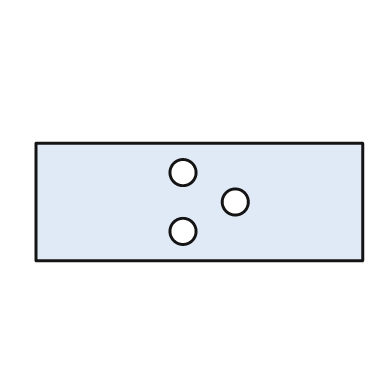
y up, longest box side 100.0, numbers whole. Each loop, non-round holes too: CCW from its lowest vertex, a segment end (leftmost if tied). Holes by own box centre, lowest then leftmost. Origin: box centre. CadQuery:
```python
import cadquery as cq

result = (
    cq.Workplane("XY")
    .moveTo(-50.0, -18.0)
    .lineTo(50.0, -18.0)
    .lineTo(50.0, 18.0)
    .lineTo(-50.0, 18.0)
    .close()
    .moveTo(-5.0, -9.0)
    .circle(4.0)
    .moveTo(11.0, 0.0)
    .circle(4.0)
    .moveTo(-5.0, 9.0)
    .circle(4.0)
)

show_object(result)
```